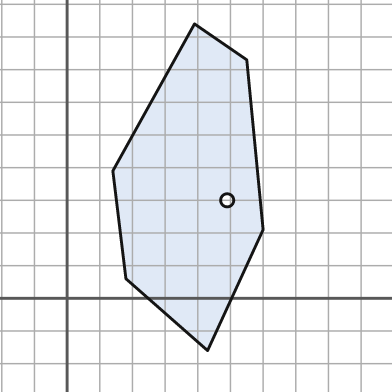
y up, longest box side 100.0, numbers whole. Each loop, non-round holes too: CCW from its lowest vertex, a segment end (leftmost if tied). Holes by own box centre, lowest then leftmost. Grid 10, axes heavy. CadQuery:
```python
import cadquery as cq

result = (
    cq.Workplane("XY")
    .moveTo(43.0, -16.0)
    .lineTo(60.0, 21.0)
    .lineTo(55.0, 73.0)
    .lineTo(39.0, 84.0)
    .lineTo(14.0, 39.0)
    .lineTo(18.0, 6.0)
    .close()
    .moveTo(49.0, 30.0)
    .circle(2.0)
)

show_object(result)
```